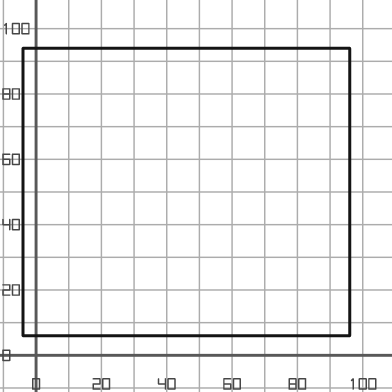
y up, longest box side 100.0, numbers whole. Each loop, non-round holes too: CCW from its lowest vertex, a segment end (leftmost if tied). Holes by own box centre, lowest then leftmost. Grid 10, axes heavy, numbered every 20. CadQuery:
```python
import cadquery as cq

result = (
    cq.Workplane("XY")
    .moveTo(-4.0, 6.0)
    .lineTo(96.0, 6.0)
    .lineTo(96.0, 94.0)
    .lineTo(-4.0, 94.0)
    .close()
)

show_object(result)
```